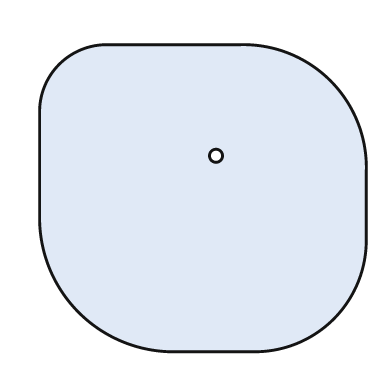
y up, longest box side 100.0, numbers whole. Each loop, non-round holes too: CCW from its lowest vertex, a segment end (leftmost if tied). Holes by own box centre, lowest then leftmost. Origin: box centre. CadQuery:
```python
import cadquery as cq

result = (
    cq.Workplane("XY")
    .moveTo(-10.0, -47.0)
    .lineTo(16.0, -47.0)
    .threePointArc((40.0, -37.0), (50.0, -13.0))
    .lineTo(50.0, 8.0)
    .threePointArc((39.0, 36.0), (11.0, 47.0))
    .lineTo(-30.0, 47.0)
    .threePointArc((-44.0, 41.0), (-50.0, 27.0))
    .lineTo(-50.0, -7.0)
    .threePointArc((-38.0, -35.0), (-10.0, -47.0))
    .close()
    .moveTo(4.0, 13.0)
    .circle(2.0)
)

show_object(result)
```